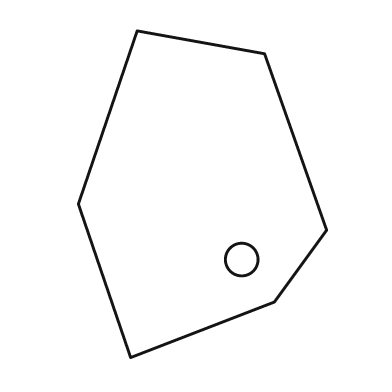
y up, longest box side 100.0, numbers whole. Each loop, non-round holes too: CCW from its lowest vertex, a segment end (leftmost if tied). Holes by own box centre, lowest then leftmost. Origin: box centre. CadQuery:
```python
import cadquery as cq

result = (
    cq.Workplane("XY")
    .moveTo(-22.0, -50.0)
    .lineTo(22.0, -33.0)
    .lineTo(38.0, -11.0)
    .lineTo(19.0, 43.0)
    .lineTo(-20.0, 50.0)
    .lineTo(-38.0, -3.0)
    .close()
    .moveTo(12.0, -20.0)
    .circle(5.0)
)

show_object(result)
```